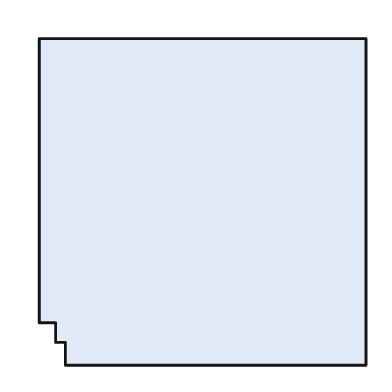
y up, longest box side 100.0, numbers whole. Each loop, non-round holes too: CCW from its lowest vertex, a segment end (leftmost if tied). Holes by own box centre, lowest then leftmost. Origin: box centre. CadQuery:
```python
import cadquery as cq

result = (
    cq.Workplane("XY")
    .moveTo(-42.0, -50.0)
    .lineTo(50.0, -50.0)
    .lineTo(50.0, 50.0)
    .lineTo(-50.0, 50.0)
    .lineTo(-50.0, -37.0)
    .lineTo(-45.0, -37.0)
    .lineTo(-45.0, -43.0)
    .lineTo(-42.0, -43.0)
    .close()
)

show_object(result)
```